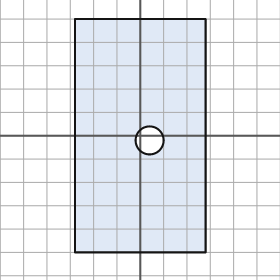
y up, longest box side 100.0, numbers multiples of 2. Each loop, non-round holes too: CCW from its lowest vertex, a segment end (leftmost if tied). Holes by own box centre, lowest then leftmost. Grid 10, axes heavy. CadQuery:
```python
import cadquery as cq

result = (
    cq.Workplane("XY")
    .moveTo(-28.0, -50.0)
    .lineTo(28.0, -50.0)
    .lineTo(28.0, 50.0)
    .lineTo(-28.0, 50.0)
    .close()
    .moveTo(4.0, -2.0)
    .circle(6.0)
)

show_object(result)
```